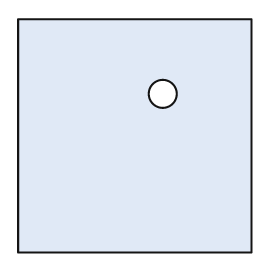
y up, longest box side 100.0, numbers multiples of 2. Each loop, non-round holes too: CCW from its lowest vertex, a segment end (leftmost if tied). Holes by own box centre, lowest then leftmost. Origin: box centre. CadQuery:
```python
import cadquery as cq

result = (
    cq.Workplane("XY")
    .moveTo(-50.0, -50.0)
    .lineTo(50.0, -50.0)
    .lineTo(50.0, 50.0)
    .lineTo(-50.0, 50.0)
    .close()
    .moveTo(12.0, 18.0)
    .circle(6.0)
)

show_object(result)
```